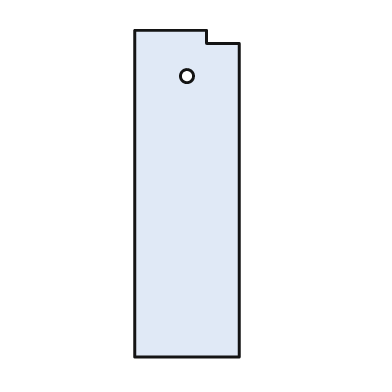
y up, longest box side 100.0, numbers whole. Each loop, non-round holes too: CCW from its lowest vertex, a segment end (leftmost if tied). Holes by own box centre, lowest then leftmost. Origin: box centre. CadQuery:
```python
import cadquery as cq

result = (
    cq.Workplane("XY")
    .moveTo(-16.0, -50.0)
    .lineTo(16.0, -50.0)
    .lineTo(16.0, 46.0)
    .lineTo(6.0, 46.0)
    .lineTo(6.0, 50.0)
    .lineTo(-16.0, 50.0)
    .close()
    .moveTo(0.0, 36.0)
    .circle(2.0)
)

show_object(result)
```